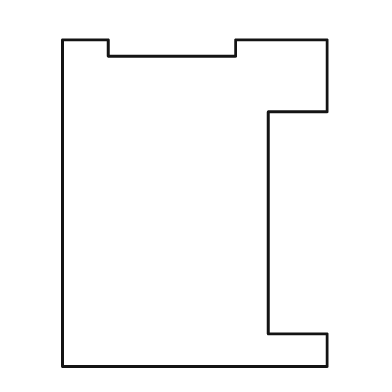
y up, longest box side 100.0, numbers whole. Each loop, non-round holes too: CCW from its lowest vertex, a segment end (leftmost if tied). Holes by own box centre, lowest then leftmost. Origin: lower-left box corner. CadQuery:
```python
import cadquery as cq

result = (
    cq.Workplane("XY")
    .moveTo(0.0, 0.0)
    .lineTo(81.0, 0.0)
    .lineTo(81.0, 10.0)
    .lineTo(63.0, 10.0)
    .lineTo(63.0, 78.0)
    .lineTo(81.0, 78.0)
    .lineTo(81.0, 100.0)
    .lineTo(53.0, 100.0)
    .lineTo(53.0, 95.0)
    .lineTo(14.0, 95.0)
    .lineTo(14.0, 100.0)
    .lineTo(0.0, 100.0)
    .close()
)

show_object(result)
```